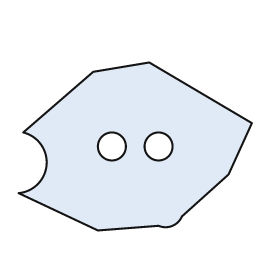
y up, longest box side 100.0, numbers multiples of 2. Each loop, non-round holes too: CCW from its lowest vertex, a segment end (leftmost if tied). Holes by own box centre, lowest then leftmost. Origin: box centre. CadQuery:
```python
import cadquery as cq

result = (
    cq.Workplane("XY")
    .moveTo(-16.0, -36.0)
    .lineTo(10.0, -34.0)
    .threePointArc((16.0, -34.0), (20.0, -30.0))
    .lineTo(40.0, -12.0)
    .lineTo(50.0, 10.0)
    .lineTo(6.0, 36.0)
    .lineTo(-18.0, 32.0)
    .lineTo(-48.0, 6.0)
    .threePointArc((-38.0, -8.0), (-50.0, -20.0))
    .close()
    .moveTo(-10.0, 0.0)
    .circle(6.0)
    .moveTo(10.0, 0.0)
    .circle(6.0)
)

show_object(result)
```